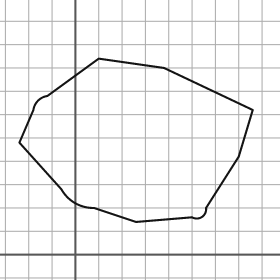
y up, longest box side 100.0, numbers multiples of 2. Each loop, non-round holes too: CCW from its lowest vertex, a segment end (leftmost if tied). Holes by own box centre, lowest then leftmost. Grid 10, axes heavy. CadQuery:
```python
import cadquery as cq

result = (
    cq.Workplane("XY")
    .moveTo(26.0, 14.0)
    .lineTo(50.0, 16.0)
    .threePointArc((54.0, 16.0), (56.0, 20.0))
    .lineTo(70.0, 42.0)
    .lineTo(76.0, 62.0)
    .lineTo(38.0, 80.0)
    .lineTo(10.0, 84.0)
    .lineTo(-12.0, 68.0)
    .threePointArc((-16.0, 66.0), (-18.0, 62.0))
    .lineTo(-24.0, 48.0)
    .lineTo(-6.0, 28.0)
    .threePointArc((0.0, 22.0), (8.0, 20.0))
    .close()
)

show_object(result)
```